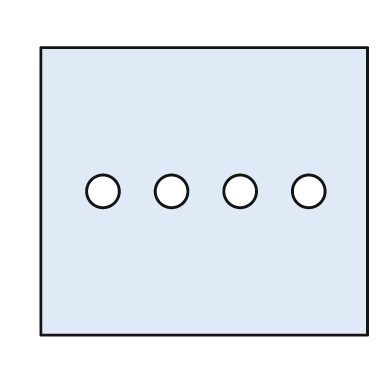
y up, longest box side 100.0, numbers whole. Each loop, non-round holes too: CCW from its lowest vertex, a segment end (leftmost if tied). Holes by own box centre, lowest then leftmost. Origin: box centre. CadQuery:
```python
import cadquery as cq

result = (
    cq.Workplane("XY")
    .moveTo(-50.0, -44.0)
    .lineTo(50.0, -44.0)
    .lineTo(50.0, 44.0)
    .lineTo(-50.0, 44.0)
    .close()
    .moveTo(-31.0, 0.0)
    .circle(5.0)
    .moveTo(-10.0, 0.0)
    .circle(5.0)
    .moveTo(11.0, 0.0)
    .circle(5.0)
    .moveTo(32.0, 0.0)
    .circle(5.0)
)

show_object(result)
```